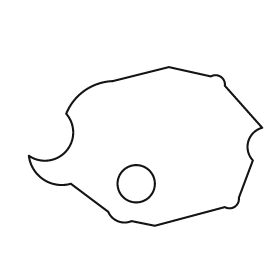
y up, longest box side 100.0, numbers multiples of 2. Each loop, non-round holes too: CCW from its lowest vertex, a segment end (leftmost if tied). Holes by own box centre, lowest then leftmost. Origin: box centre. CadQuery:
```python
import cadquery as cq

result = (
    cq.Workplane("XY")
    .moveTo(4.0, -34.0)
    .lineTo(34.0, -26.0)
    .threePointArc((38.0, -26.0), (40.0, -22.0))
    .lineTo(46.0, -6.0)
    .threePointArc((44.0, 2.0), (50.0, 8.0))
    .lineTo(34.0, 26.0)
    .threePointArc((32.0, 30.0), (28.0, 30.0))
    .lineTo(10.0, 34.0)
    .lineTo(-14.0, 28.0)
    .threePointArc((-26.0, 24.0), (-34.0, 14.0))
    .threePointArc((-34.0, -2.0), (-50.0, -4.0))
    .threePointArc((-44.0, -14.0), (-32.0, -16.0))
    .lineTo(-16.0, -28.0)
    .threePointArc((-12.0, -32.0), (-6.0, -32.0))
    .close()
    .moveTo(-4.0, -16.0)
    .circle(8.0)
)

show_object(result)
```